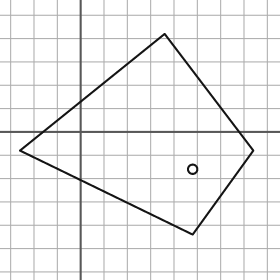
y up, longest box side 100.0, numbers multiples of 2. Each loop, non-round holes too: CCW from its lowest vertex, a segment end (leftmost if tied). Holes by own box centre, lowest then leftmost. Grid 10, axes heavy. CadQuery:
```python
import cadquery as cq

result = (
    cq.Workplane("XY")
    .moveTo(48.0, -44.0)
    .lineTo(74.0, -8.0)
    .lineTo(36.0, 42.0)
    .lineTo(-26.0, -8.0)
    .close()
    .moveTo(48.0, -16.0)
    .circle(2.0)
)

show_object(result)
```